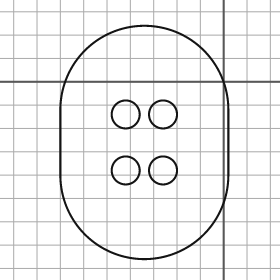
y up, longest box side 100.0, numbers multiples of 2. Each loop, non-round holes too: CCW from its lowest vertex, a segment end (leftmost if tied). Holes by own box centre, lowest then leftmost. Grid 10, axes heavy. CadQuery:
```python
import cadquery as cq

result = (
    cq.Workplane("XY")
    .moveTo(-70.0, -40.0)
    .threePointArc((-34.0, -76.0), (2.0, -40.0))
    .lineTo(2.0, -12.0)
    .threePointArc((-34.0, 24.0), (-70.0, -12.0))
    .close()
    .moveTo(-42.0, -38.0)
    .circle(6.0)
    .moveTo(-26.0, -38.0)
    .circle(6.0)
    .moveTo(-42.0, -14.0)
    .circle(6.0)
    .moveTo(-26.0, -14.0)
    .circle(6.0)
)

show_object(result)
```